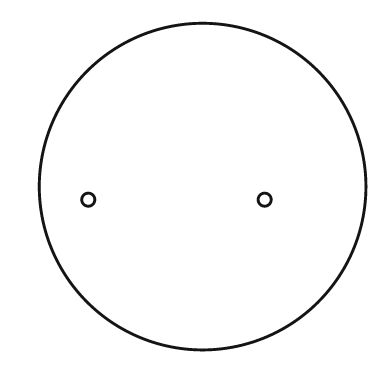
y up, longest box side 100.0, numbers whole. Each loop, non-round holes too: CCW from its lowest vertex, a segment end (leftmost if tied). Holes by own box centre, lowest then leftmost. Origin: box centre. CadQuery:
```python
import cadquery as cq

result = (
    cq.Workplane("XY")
    .moveTo(0.0, 0.0)
    .circle(50.0)
    .moveTo(-35.0, -4.0)
    .circle(2.0)
    .moveTo(19.0, -4.0)
    .circle(2.0)
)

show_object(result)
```